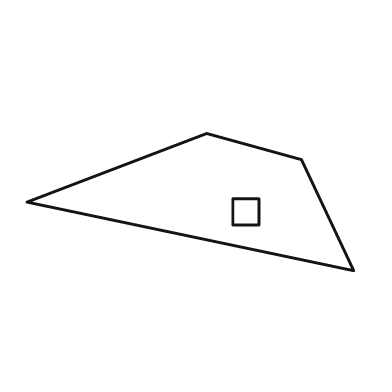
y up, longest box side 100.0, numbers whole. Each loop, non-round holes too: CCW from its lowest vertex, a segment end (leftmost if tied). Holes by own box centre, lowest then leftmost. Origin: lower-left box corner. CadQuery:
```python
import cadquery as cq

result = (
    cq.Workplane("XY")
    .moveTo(100.0, 0.0)
    .lineTo(84.0, 34.0)
    .lineTo(55.0, 42.0)
    .lineTo(0.0, 21.0)
    .close()
    .moveTo(63.0, 14.0)
    .lineTo(71.0, 14.0)
    .lineTo(71.0, 22.0)
    .lineTo(63.0, 22.0)
    .close()
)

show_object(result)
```